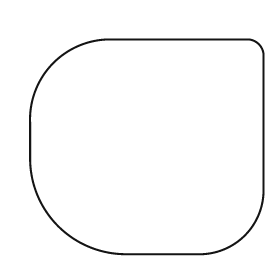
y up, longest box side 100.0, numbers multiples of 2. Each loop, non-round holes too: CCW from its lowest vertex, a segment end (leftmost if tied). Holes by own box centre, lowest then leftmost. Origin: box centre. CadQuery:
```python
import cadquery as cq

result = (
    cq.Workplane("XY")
    .moveTo(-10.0, -46.0)
    .lineTo(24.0, -46.0)
    .threePointArc((42.0, -38.0), (50.0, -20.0))
    .lineTo(50.0, 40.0)
    .threePointArc((48.0, 44.0), (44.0, 46.0))
    .lineTo(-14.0, 46.0)
    .threePointArc((-40.0, 36.0), (-50.0, 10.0))
    .lineTo(-50.0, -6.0)
    .threePointArc((-38.0, -34.0), (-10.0, -46.0))
    .close()
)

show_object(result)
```